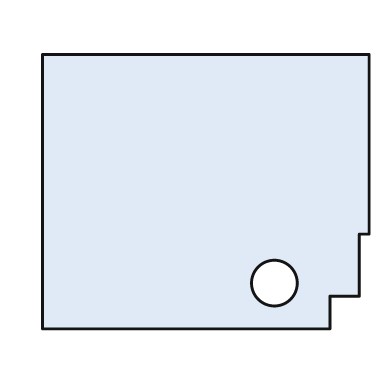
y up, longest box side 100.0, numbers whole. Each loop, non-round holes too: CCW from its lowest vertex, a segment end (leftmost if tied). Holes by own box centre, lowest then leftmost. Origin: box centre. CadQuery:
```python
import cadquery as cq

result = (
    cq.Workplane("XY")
    .moveTo(-50.0, -42.0)
    .lineTo(38.0, -42.0)
    .lineTo(38.0, -32.0)
    .lineTo(47.0, -32.0)
    .lineTo(47.0, -13.0)
    .lineTo(50.0, -13.0)
    .lineTo(50.0, 42.0)
    .lineTo(-50.0, 42.0)
    .close()
    .moveTo(21.0, -28.0)
    .circle(7.0)
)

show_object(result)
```